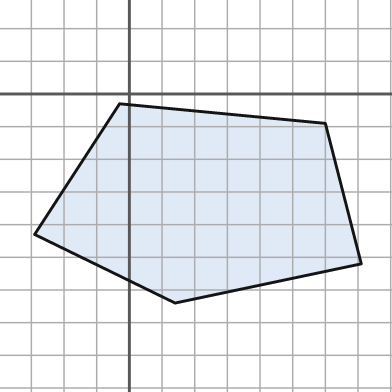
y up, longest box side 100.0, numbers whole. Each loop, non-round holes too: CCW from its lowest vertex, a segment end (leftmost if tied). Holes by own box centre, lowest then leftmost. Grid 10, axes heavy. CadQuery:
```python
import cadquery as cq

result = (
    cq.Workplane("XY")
    .moveTo(14.0, -64.0)
    .lineTo(71.0, -52.0)
    .lineTo(60.0, -9.0)
    .lineTo(-3.0, -3.0)
    .lineTo(-29.0, -43.0)
    .close()
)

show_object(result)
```